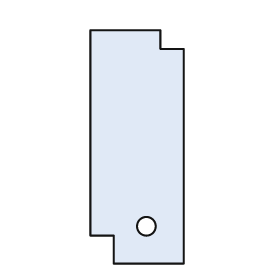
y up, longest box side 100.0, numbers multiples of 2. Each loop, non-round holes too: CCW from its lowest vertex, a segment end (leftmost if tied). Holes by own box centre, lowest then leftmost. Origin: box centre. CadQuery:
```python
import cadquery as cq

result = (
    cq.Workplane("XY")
    .moveTo(-10.0, -50.0)
    .lineTo(20.0, -50.0)
    .lineTo(20.0, 42.0)
    .lineTo(10.0, 42.0)
    .lineTo(10.0, 50.0)
    .lineTo(-20.0, 50.0)
    .lineTo(-20.0, -38.0)
    .lineTo(-10.0, -38.0)
    .close()
    .moveTo(4.0, -34.0)
    .circle(4.0)
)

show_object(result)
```